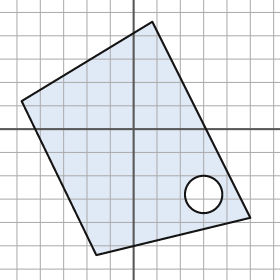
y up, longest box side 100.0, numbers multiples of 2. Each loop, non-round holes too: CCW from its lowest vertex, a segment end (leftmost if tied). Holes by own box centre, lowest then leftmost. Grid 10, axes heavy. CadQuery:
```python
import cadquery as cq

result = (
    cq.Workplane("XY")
    .moveTo(-16.0, -54.0)
    .lineTo(50.0, -38.0)
    .lineTo(8.0, 46.0)
    .lineTo(-48.0, 12.0)
    .close()
    .moveTo(30.0, -28.0)
    .circle(8.0)
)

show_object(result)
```